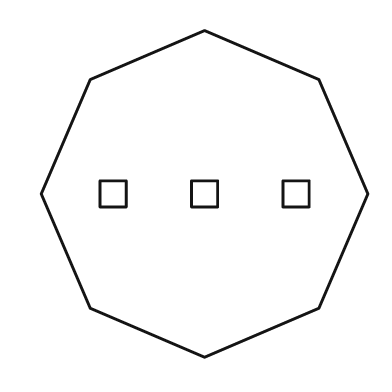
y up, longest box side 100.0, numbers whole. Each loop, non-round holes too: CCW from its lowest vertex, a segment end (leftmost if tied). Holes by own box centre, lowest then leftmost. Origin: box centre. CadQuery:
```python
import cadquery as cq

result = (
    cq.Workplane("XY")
    .moveTo(0.0, -50.0)
    .lineTo(35.0, -35.0)
    .lineTo(50.0, 0.0)
    .lineTo(35.0, 35.0)
    .lineTo(0.0, 50.0)
    .lineTo(-35.0, 35.0)
    .lineTo(-50.0, 0.0)
    .lineTo(-35.0, -35.0)
    .close()
    .moveTo(-32.0, -4.0)
    .lineTo(-24.0, -4.0)
    .lineTo(-24.0, 4.0)
    .lineTo(-32.0, 4.0)
    .close()
    .moveTo(-4.0, -4.0)
    .lineTo(4.0, -4.0)
    .lineTo(4.0, 4.0)
    .lineTo(-4.0, 4.0)
    .close()
    .moveTo(24.0, -4.0)
    .lineTo(32.0, -4.0)
    .lineTo(32.0, 4.0)
    .lineTo(24.0, 4.0)
    .close()
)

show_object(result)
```